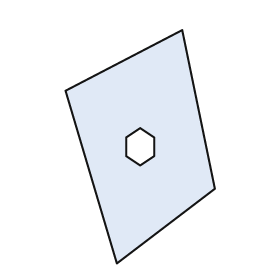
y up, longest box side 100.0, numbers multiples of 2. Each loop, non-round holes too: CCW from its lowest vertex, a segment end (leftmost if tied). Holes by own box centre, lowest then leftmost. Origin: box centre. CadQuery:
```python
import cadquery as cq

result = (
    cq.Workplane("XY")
    .moveTo(-10.0, -50.0)
    .lineTo(32.0, -18.0)
    .lineTo(18.0, 50.0)
    .lineTo(-32.0, 24.0)
    .close()
    .moveTo(0.0, -8.0)
    .lineTo(6.0, -4.0)
    .lineTo(6.0, 4.0)
    .lineTo(0.0, 8.0)
    .lineTo(-6.0, 4.0)
    .lineTo(-6.0, -4.0)
    .close()
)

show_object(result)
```